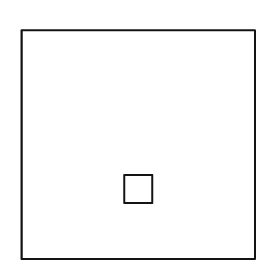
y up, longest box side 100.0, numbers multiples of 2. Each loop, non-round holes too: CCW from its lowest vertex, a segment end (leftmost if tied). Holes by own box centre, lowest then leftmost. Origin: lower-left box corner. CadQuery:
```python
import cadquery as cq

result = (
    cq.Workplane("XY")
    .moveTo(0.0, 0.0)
    .lineTo(100.0, 0.0)
    .lineTo(100.0, 98.0)
    .lineTo(0.0, 98.0)
    .close()
    .moveTo(44.0, 24.0)
    .lineTo(56.0, 24.0)
    .lineTo(56.0, 36.0)
    .lineTo(44.0, 36.0)
    .close()
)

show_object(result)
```